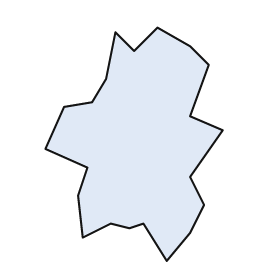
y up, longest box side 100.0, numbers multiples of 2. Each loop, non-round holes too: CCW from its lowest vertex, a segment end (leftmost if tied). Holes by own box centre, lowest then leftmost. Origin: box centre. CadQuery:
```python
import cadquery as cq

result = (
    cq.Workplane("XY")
    .moveTo(14.0, -50.0)
    .lineTo(24.0, -38.0)
    .lineTo(30.0, -26.0)
    .lineTo(24.0, -14.0)
    .lineTo(38.0, 6.0)
    .lineTo(24.0, 12.0)
    .lineTo(32.0, 34.0)
    .lineTo(24.0, 42.0)
    .lineTo(10.0, 50.0)
    .lineTo(0.0, 40.0)
    .lineTo(-8.0, 48.0)
    .lineTo(-12.0, 28.0)
    .lineTo(-18.0, 18.0)
    .lineTo(-30.0, 16.0)
    .lineTo(-38.0, -2.0)
    .lineTo(-20.0, -10.0)
    .lineTo(-24.0, -22.0)
    .lineTo(-22.0, -40.0)
    .lineTo(-10.0, -34.0)
    .lineTo(-2.0, -36.0)
    .lineTo(4.0, -34.0)
    .close()
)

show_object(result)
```